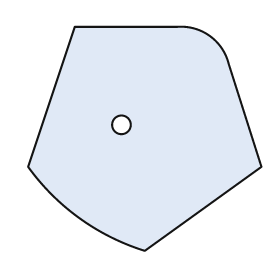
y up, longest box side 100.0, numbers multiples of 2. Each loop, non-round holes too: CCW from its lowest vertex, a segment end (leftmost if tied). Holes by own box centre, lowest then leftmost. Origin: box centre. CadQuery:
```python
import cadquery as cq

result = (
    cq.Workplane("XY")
    .moveTo(0.0, -48.0)
    .lineTo(50.0, -12.0)
    .lineTo(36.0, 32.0)
    .threePointArc((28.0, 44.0), (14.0, 48.0))
    .lineTo(-30.0, 48.0)
    .lineTo(-50.0, -12.0)
    .threePointArc((-28.0, -34.0), (0.0, -48.0))
    .close()
    .moveTo(-10.0, 6.0)
    .circle(4.0)
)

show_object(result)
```